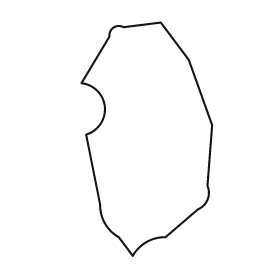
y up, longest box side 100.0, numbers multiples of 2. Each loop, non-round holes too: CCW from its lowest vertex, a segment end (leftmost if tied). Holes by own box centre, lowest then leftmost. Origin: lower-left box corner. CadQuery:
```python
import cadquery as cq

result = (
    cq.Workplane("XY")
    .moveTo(22.0, 0.0)
    .threePointArc((28.0, 6.0), (36.0, 8.0))
    .lineTo(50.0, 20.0)
    .threePointArc((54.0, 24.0), (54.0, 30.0))
    .lineTo(56.0, 56.0)
    .lineTo(46.0, 84.0)
    .lineTo(34.0, 100.0)
    .lineTo(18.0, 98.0)
    .threePointArc((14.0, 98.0), (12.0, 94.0))
    .lineTo(0.0, 74.0)
    .threePointArc((10.0, 64.0), (2.0, 52.0))
    .lineTo(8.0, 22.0)
    .threePointArc((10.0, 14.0), (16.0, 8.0))
    .close()
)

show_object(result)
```